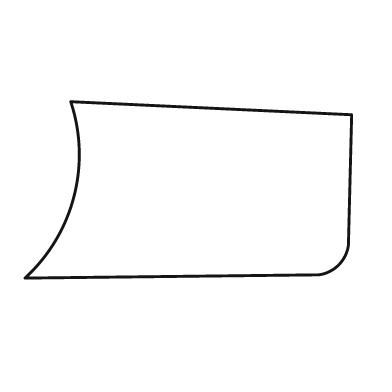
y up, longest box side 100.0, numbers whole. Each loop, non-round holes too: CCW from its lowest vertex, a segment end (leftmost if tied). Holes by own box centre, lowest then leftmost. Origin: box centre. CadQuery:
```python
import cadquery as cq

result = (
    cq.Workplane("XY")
    .moveTo(-50.0, -27.0)
    .lineTo(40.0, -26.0)
    .threePointArc((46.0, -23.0), (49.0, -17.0))
    .lineTo(50.0, 23.0)
    .lineTo(-36.0, 27.0)
    .threePointArc((-35.0, -2.0), (-50.0, -27.0))
    .close()
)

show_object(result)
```